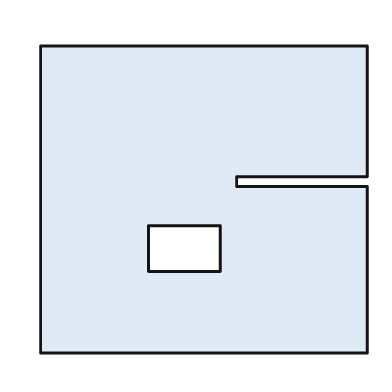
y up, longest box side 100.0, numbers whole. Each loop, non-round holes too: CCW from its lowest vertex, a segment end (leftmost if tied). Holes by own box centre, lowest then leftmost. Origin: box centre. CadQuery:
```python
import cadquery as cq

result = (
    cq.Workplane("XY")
    .moveTo(-50.0, -47.0)
    .lineTo(50.0, -47.0)
    .lineTo(50.0, 4.0)
    .lineTo(10.0, 4.0)
    .lineTo(10.0, 7.0)
    .lineTo(50.0, 7.0)
    .lineTo(50.0, 47.0)
    .lineTo(-50.0, 47.0)
    .close()
    .moveTo(-17.0, -22.0)
    .lineTo(5.0, -22.0)
    .lineTo(5.0, -8.0)
    .lineTo(-17.0, -8.0)
    .close()
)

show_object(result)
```